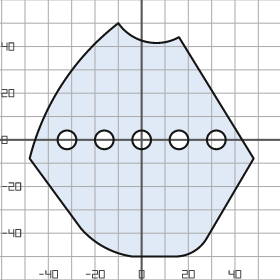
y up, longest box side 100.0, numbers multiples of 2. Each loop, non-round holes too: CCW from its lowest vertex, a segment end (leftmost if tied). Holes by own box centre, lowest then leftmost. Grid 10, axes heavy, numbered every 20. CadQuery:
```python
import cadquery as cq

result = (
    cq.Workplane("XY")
    .moveTo(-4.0, -50.0)
    .lineTo(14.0, -50.0)
    .threePointArc((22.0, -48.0), (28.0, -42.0))
    .lineTo(48.0, -8.0)
    .lineTo(16.0, 44.0)
    .threePointArc((2.0, 42.0), (-10.0, 50.0))
    .threePointArc((-34.0, 24.0), (-48.0, -8.0))
    .lineTo(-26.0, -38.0)
    .threePointArc((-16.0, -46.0), (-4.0, -50.0))
    .close()
    .moveTo(-32.0, 0.0)
    .circle(4.0)
    .moveTo(-16.0, 0.0)
    .circle(4.0)
    .moveTo(0.0, 0.0)
    .circle(4.0)
    .moveTo(16.0, 0.0)
    .circle(4.0)
    .moveTo(32.0, 0.0)
    .circle(4.0)
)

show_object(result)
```